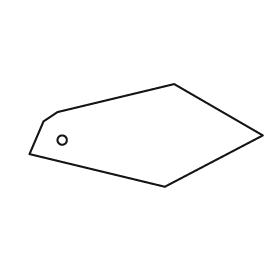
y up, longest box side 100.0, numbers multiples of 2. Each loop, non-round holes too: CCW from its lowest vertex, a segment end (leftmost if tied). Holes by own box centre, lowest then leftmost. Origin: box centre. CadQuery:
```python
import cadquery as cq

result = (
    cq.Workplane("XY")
    .moveTo(8.0, -22.0)
    .lineTo(50.0, 0.0)
    .lineTo(12.0, 22.0)
    .lineTo(-38.0, 10.0)
    .lineTo(-44.0, 6.0)
    .lineTo(-50.0, -8.0)
    .close()
    .moveTo(-36.0, -2.0)
    .circle(2.0)
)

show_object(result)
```